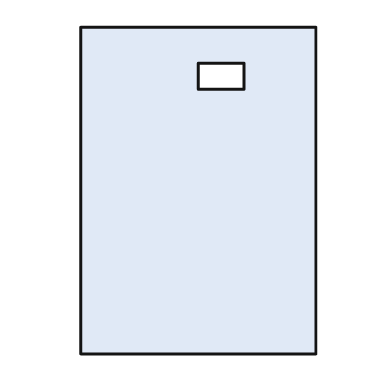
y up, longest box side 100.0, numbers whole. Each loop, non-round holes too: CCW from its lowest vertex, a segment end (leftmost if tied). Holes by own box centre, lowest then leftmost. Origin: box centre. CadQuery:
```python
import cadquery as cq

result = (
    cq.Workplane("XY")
    .moveTo(-36.0, -50.0)
    .lineTo(36.0, -50.0)
    .lineTo(36.0, 50.0)
    .lineTo(-36.0, 50.0)
    .close()
    .moveTo(0.0, 31.0)
    .lineTo(14.0, 31.0)
    .lineTo(14.0, 39.0)
    .lineTo(0.0, 39.0)
    .close()
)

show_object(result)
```